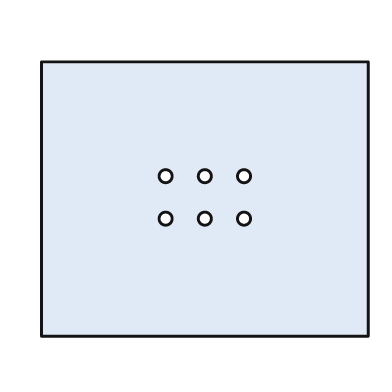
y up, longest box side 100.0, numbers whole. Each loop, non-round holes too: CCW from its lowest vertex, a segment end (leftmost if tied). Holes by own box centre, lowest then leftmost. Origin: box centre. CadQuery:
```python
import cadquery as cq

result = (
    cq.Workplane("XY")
    .moveTo(-50.0, -42.0)
    .lineTo(50.0, -42.0)
    .lineTo(50.0, 42.0)
    .lineTo(-50.0, 42.0)
    .close()
    .moveTo(-12.0, -6.0)
    .circle(2.0)
    .moveTo(0.0, -6.0)
    .circle(2.0)
    .moveTo(12.0, -6.0)
    .circle(2.0)
    .moveTo(-12.0, 7.0)
    .circle(2.0)
    .moveTo(0.0, 7.0)
    .circle(2.0)
    .moveTo(12.0, 7.0)
    .circle(2.0)
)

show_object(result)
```